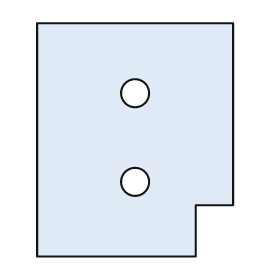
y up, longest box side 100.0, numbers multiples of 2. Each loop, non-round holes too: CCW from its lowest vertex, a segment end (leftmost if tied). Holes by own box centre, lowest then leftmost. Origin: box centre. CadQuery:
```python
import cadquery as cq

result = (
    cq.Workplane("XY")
    .moveTo(-42.0, -50.0)
    .lineTo(26.0, -50.0)
    .lineTo(26.0, -28.0)
    .lineTo(42.0, -28.0)
    .lineTo(42.0, 50.0)
    .lineTo(-42.0, 50.0)
    .close()
    .moveTo(0.0, -18.0)
    .circle(6.0)
    .moveTo(0.0, 20.0)
    .circle(6.0)
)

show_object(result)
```